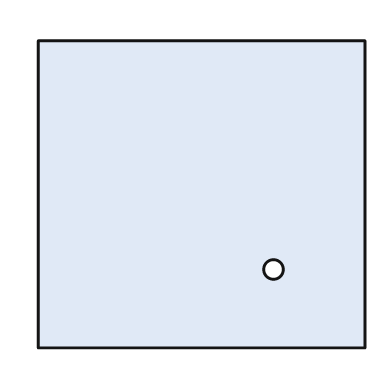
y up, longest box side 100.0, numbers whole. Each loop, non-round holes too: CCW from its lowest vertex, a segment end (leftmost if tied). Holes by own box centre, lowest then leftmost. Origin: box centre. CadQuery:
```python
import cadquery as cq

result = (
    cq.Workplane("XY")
    .moveTo(-50.0, -47.0)
    .lineTo(50.0, -47.0)
    .lineTo(50.0, 47.0)
    .lineTo(-50.0, 47.0)
    .close()
    .moveTo(22.0, -23.0)
    .circle(3.0)
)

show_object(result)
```